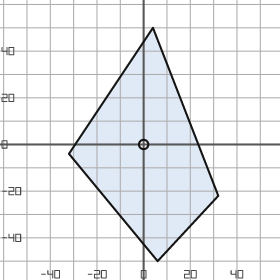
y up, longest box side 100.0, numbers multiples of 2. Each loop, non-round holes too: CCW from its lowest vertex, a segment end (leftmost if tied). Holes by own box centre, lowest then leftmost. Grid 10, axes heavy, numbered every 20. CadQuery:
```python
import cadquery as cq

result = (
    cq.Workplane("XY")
    .moveTo(6.0, -50.0)
    .lineTo(32.0, -22.0)
    .lineTo(4.0, 50.0)
    .lineTo(-32.0, -4.0)
    .close()
    .moveTo(0.0, 0.0)
    .circle(2.0)
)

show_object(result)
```